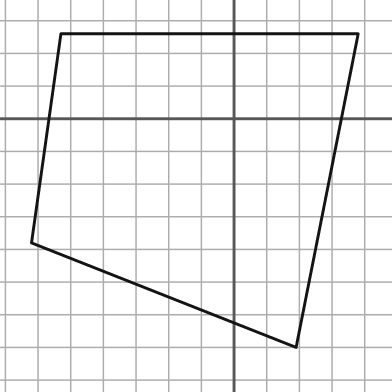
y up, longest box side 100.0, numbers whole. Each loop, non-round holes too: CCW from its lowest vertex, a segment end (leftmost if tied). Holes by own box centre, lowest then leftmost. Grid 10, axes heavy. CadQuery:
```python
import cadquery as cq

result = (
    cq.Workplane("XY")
    .moveTo(19.0, -70.0)
    .lineTo(38.0, 26.0)
    .lineTo(-53.0, 26.0)
    .lineTo(-62.0, -38.0)
    .close()
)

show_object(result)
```